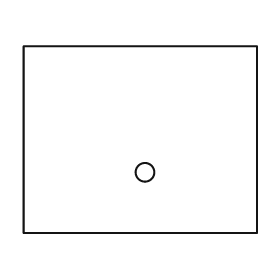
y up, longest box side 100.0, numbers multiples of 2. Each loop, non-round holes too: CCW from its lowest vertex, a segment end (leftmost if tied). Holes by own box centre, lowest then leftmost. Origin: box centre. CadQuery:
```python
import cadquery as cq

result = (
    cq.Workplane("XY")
    .moveTo(-50.0, -40.0)
    .lineTo(50.0, -40.0)
    .lineTo(50.0, 40.0)
    .lineTo(-50.0, 40.0)
    .close()
    .moveTo(2.0, -14.0)
    .circle(4.0)
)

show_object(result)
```